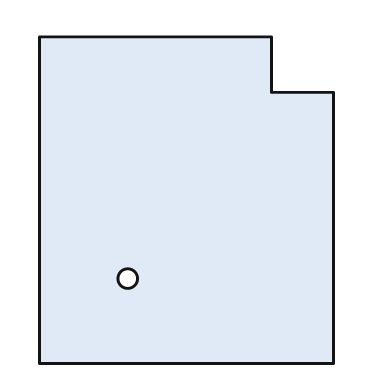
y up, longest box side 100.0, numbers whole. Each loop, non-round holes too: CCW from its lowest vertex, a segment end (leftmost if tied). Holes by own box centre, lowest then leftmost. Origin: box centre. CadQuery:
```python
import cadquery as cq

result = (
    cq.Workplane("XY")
    .moveTo(-45.0, -50.0)
    .lineTo(45.0, -50.0)
    .lineTo(45.0, 33.0)
    .lineTo(26.0, 33.0)
    .lineTo(26.0, 50.0)
    .lineTo(-45.0, 50.0)
    .close()
    .moveTo(-18.0, -24.0)
    .circle(3.0)
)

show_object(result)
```